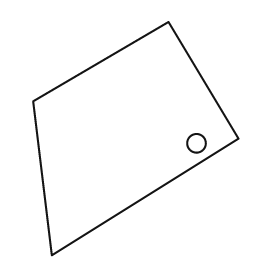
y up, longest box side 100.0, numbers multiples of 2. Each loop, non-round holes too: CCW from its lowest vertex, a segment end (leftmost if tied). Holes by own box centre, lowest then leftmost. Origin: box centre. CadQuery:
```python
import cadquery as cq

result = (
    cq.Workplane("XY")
    .moveTo(-36.0, -50.0)
    .lineTo(44.0, 0.0)
    .lineTo(14.0, 50.0)
    .lineTo(-44.0, 16.0)
    .close()
    .moveTo(26.0, -2.0)
    .circle(4.0)
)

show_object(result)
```